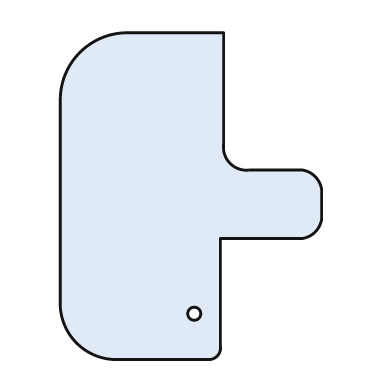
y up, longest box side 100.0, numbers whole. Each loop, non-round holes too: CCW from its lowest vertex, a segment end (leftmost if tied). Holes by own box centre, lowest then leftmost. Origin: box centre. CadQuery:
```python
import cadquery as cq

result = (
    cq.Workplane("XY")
    .moveTo(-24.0, -50.0)
    .lineTo(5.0, -50.0)
    .threePointArc((8.0, -49.0), (9.0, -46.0))
    .lineTo(9.0, -13.0)
    .lineTo(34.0, -13.0)
    .threePointArc((38.0, -11.0), (40.0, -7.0))
    .lineTo(40.0, 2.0)
    .threePointArc((38.0, 6.0), (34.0, 8.0))
    .lineTo(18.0, 8.0)
    .threePointArc((12.0, 10.0), (10.0, 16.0))
    .lineTo(10.0, 50.0)
    .lineTo(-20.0, 50.0)
    .threePointArc((-34.0, 44.0), (-40.0, 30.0))
    .lineTo(-40.0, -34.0)
    .threePointArc((-35.0, -45.0), (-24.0, -50.0))
    .close()
    .moveTo(1.0, -36.0)
    .circle(2.0)
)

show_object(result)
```